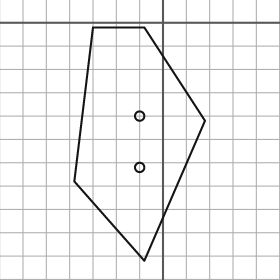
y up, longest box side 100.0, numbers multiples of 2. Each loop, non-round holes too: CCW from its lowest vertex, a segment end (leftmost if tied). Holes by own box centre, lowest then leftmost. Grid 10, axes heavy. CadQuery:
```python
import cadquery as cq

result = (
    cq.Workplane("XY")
    .moveTo(-8.0, -102.0)
    .lineTo(18.0, -42.0)
    .lineTo(-8.0, -2.0)
    .lineTo(-30.0, -2.0)
    .lineTo(-38.0, -68.0)
    .close()
    .moveTo(-10.0, -62.0)
    .circle(2.0)
    .moveTo(-10.0, -40.0)
    .circle(2.0)
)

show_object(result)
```